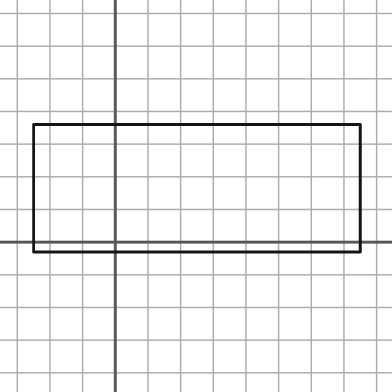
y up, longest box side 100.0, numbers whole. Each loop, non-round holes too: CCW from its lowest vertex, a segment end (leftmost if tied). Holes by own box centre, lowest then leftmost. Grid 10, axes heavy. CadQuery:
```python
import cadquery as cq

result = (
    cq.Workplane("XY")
    .moveTo(-25.0, -3.0)
    .lineTo(75.0, -3.0)
    .lineTo(75.0, 36.0)
    .lineTo(-25.0, 36.0)
    .close()
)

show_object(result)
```